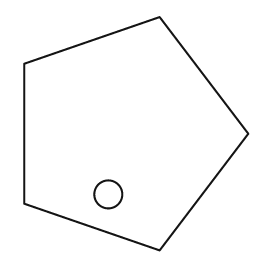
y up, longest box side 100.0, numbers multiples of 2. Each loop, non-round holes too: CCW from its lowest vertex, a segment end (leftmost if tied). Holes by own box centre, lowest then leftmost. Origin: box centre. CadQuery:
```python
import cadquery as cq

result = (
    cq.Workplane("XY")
    .moveTo(10.0, -50.0)
    .lineTo(48.0, 0.0)
    .lineTo(10.0, 50.0)
    .lineTo(-48.0, 30.0)
    .lineTo(-48.0, -30.0)
    .close()
    .moveTo(-12.0, -26.0)
    .circle(6.0)
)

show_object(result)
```